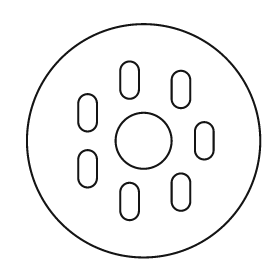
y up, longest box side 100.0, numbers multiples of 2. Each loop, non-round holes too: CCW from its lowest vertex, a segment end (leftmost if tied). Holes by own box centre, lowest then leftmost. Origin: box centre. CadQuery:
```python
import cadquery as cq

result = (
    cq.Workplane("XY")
    .moveTo(0.0, 0.0)
    .circle(50.0)
    .moveTo(-10.0, -30.0)
    .threePointArc((-6.0, -34.0), (-2.0, -30.0))
    .lineTo(-2.0, -22.0)
    .threePointArc((-6.0, -18.0), (-10.0, -22.0))
    .close()
    .moveTo(12.0, -26.0)
    .threePointArc((16.0, -30.0), (20.0, -26.0))
    .lineTo(20.0, -18.0)
    .threePointArc((16.0, -14.0), (12.0, -18.0))
    .close()
    .moveTo(-28.0, -16.0)
    .threePointArc((-24.0, -20.0), (-20.0, -16.0))
    .lineTo(-20.0, -8.0)
    .threePointArc((-24.0, -4.0), (-28.0, -8.0))
    .close()
    .moveTo(0.0, 0.0)
    .circle(12.0)
    .moveTo(22.0, -4.0)
    .threePointArc((26.0, -8.0), (30.0, -4.0))
    .lineTo(30.0, 4.0)
    .threePointArc((26.0, 8.0), (22.0, 4.0))
    .close()
    .moveTo(-28.0, 8.0)
    .threePointArc((-24.0, 4.0), (-20.0, 8.0))
    .lineTo(-20.0, 16.0)
    .threePointArc((-24.0, 20.0), (-28.0, 16.0))
    .close()
    .moveTo(12.0, 18.0)
    .threePointArc((16.0, 14.0), (20.0, 18.0))
    .lineTo(20.0, 26.0)
    .threePointArc((16.0, 30.0), (12.0, 26.0))
    .close()
    .moveTo(-10.0, 22.0)
    .threePointArc((-6.0, 18.0), (-2.0, 22.0))
    .lineTo(-2.0, 30.0)
    .threePointArc((-6.0, 34.0), (-10.0, 30.0))
    .close()
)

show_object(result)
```